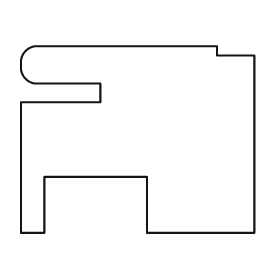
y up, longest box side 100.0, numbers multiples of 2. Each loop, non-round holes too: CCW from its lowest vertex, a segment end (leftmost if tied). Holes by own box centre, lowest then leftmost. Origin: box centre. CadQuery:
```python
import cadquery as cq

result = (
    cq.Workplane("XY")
    .moveTo(-50.0, -40.0)
    .lineTo(-40.0, -40.0)
    .lineTo(-40.0, -16.0)
    .lineTo(4.0, -16.0)
    .lineTo(4.0, -40.0)
    .lineTo(50.0, -40.0)
    .lineTo(50.0, 36.0)
    .lineTo(34.0, 36.0)
    .lineTo(34.0, 40.0)
    .lineTo(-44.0, 40.0)
    .threePointArc((-48.0, 38.0), (-50.0, 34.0))
    .lineTo(-50.0, 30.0)
    .threePointArc((-48.0, 26.0), (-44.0, 24.0))
    .lineTo(-16.0, 24.0)
    .lineTo(-16.0, 16.0)
    .lineTo(-50.0, 16.0)
    .close()
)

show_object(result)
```